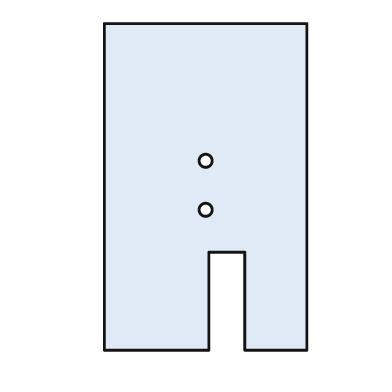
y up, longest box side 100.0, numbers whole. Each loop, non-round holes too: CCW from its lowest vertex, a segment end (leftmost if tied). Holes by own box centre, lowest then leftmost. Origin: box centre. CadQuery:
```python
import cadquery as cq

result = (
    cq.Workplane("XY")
    .moveTo(-31.0, -50.0)
    .lineTo(1.0, -50.0)
    .lineTo(1.0, -20.0)
    .lineTo(12.0, -20.0)
    .lineTo(12.0, -50.0)
    .lineTo(31.0, -50.0)
    .lineTo(31.0, 50.0)
    .lineTo(-31.0, 50.0)
    .close()
    .moveTo(0.0, -7.0)
    .circle(2.0)
    .moveTo(0.0, 8.0)
    .circle(2.0)
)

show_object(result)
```